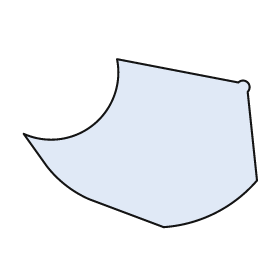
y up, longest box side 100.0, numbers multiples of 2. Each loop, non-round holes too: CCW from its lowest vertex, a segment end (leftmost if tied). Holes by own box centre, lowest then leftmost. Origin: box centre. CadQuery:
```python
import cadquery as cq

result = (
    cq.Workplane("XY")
    .moveTo(10.0, -36.0)
    .threePointArc((32.0, -30.0), (50.0, -16.0))
    .lineTo(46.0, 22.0)
    .threePointArc((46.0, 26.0), (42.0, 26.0))
    .lineTo(-10.0, 36.0)
    .threePointArc((-20.0, 8.0), (-50.0, 4.0))
    .lineTo(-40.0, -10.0)
    .threePointArc((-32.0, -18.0), (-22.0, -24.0))
    .close()
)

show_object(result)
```